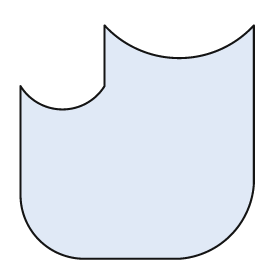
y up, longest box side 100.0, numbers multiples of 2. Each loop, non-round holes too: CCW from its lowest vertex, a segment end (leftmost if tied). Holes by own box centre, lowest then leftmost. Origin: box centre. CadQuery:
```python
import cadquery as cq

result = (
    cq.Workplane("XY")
    .moveTo(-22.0, -50.0)
    .lineTo(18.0, -50.0)
    .threePointArc((40.0, -40.0), (50.0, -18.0))
    .lineTo(50.0, 50.0)
    .threePointArc((18.0, 36.0), (-14.0, 50.0))
    .lineTo(-14.0, 24.0)
    .threePointArc((-32.0, 14.0), (-50.0, 24.0))
    .lineTo(-50.0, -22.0)
    .threePointArc((-42.0, -42.0), (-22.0, -50.0))
    .close()
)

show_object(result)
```